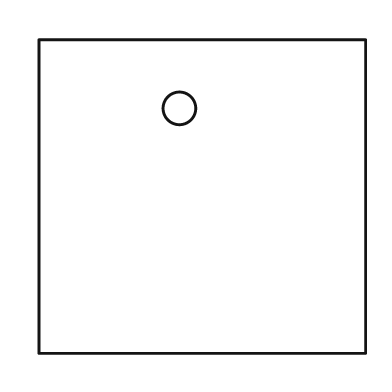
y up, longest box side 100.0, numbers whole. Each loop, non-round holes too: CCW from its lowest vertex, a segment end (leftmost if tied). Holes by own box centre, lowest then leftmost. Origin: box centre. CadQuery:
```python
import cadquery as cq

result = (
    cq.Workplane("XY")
    .moveTo(-50.0, -48.0)
    .lineTo(50.0, -48.0)
    .lineTo(50.0, 48.0)
    .lineTo(-50.0, 48.0)
    .close()
    .moveTo(-7.0, 27.0)
    .circle(5.0)
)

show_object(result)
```